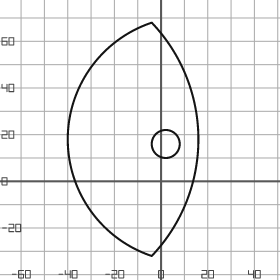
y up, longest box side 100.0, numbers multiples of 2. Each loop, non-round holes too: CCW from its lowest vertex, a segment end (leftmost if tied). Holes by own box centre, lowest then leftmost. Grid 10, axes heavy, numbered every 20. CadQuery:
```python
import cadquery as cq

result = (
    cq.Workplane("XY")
    .moveTo(-4.0, -32.0)
    .threePointArc((16.0, 18.0), (-4.0, 68.0))
    .threePointArc((-40.0, 18.0), (-4.0, -32.0))
    .close()
    .moveTo(2.0, 16.0)
    .circle(6.0)
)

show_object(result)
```